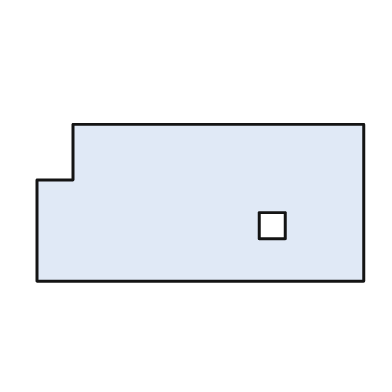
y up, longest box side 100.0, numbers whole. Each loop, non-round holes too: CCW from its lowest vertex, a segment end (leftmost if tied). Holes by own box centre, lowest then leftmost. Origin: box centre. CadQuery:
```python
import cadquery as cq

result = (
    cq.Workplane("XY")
    .moveTo(-50.0, -24.0)
    .lineTo(50.0, -24.0)
    .lineTo(50.0, 24.0)
    .lineTo(-39.0, 24.0)
    .lineTo(-39.0, 7.0)
    .lineTo(-50.0, 7.0)
    .close()
    .moveTo(18.0, -11.0)
    .lineTo(26.0, -11.0)
    .lineTo(26.0, -3.0)
    .lineTo(18.0, -3.0)
    .close()
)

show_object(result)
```